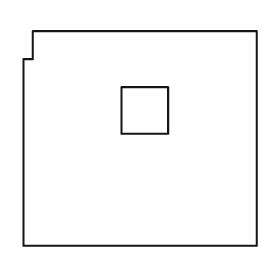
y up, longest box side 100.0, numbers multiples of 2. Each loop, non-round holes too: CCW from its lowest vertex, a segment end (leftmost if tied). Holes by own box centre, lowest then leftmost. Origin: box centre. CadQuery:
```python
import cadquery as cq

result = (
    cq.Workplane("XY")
    .moveTo(-50.0, -46.0)
    .lineTo(50.0, -46.0)
    .lineTo(50.0, 46.0)
    .lineTo(-46.0, 46.0)
    .lineTo(-46.0, 34.0)
    .lineTo(-50.0, 34.0)
    .close()
    .moveTo(-8.0, 2.0)
    .lineTo(12.0, 2.0)
    .lineTo(12.0, 22.0)
    .lineTo(-8.0, 22.0)
    .close()
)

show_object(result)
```